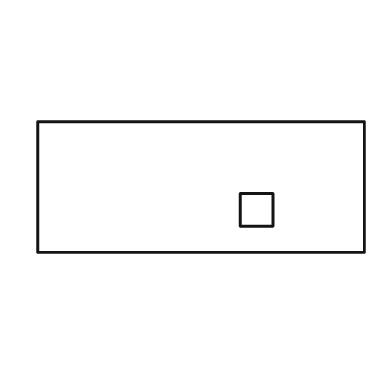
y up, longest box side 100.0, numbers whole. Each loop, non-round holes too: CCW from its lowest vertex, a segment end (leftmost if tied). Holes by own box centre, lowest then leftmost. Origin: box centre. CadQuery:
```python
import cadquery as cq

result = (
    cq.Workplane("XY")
    .moveTo(-50.0, -20.0)
    .lineTo(50.0, -20.0)
    .lineTo(50.0, 20.0)
    .lineTo(-50.0, 20.0)
    .close()
    .moveTo(12.0, -12.0)
    .lineTo(22.0, -12.0)
    .lineTo(22.0, -2.0)
    .lineTo(12.0, -2.0)
    .close()
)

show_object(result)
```